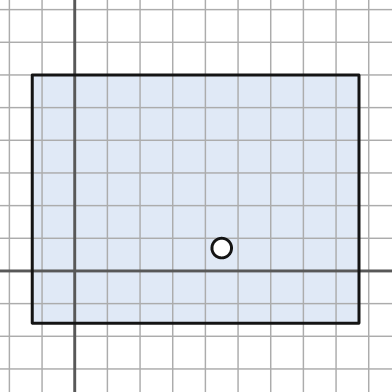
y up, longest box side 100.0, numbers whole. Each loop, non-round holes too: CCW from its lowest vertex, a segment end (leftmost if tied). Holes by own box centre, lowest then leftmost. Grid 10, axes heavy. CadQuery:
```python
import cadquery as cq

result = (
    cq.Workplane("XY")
    .moveTo(-13.0, -16.0)
    .lineTo(87.0, -16.0)
    .lineTo(87.0, 60.0)
    .lineTo(-13.0, 60.0)
    .close()
    .moveTo(45.0, 7.0)
    .circle(3.0)
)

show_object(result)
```